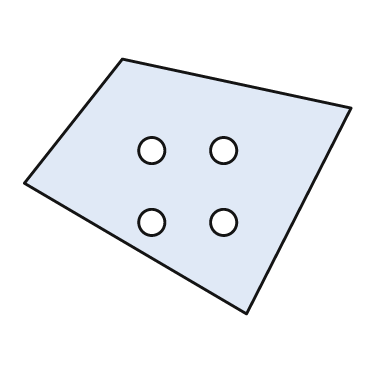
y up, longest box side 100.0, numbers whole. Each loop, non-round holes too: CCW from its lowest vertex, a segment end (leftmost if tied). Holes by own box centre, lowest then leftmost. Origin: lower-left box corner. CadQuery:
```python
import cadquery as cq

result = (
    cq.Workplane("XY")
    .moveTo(68.0, 0.0)
    .lineTo(100.0, 63.0)
    .lineTo(30.0, 78.0)
    .lineTo(0.0, 40.0)
    .close()
    .moveTo(39.0, 28.0)
    .circle(4.0)
    .moveTo(61.0, 28.0)
    .circle(4.0)
    .moveTo(39.0, 50.0)
    .circle(4.0)
    .moveTo(61.0, 50.0)
    .circle(4.0)
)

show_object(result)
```